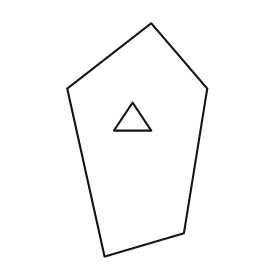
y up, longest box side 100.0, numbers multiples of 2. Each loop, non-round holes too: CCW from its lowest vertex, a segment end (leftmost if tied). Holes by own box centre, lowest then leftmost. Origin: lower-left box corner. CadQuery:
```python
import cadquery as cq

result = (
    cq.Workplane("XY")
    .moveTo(16.0, 0.0)
    .lineTo(50.0, 10.0)
    .lineTo(60.0, 72.0)
    .lineTo(36.0, 100.0)
    .lineTo(0.0, 72.0)
    .close()
    .moveTo(20.0, 54.0)
    .lineTo(36.0, 54.0)
    .lineTo(28.0, 66.0)
    .close()
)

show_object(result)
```